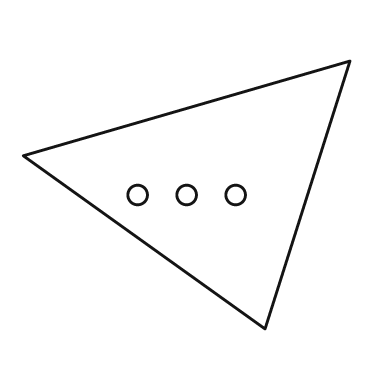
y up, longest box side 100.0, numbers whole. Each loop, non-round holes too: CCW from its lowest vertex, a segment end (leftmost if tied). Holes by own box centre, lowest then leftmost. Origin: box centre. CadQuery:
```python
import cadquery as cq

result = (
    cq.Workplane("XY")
    .moveTo(24.0, -41.0)
    .lineTo(50.0, 41.0)
    .lineTo(-50.0, 12.0)
    .close()
    .moveTo(-15.0, 0.0)
    .circle(3.0)
    .moveTo(0.0, 0.0)
    .circle(3.0)
    .moveTo(15.0, 0.0)
    .circle(3.0)
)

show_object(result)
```